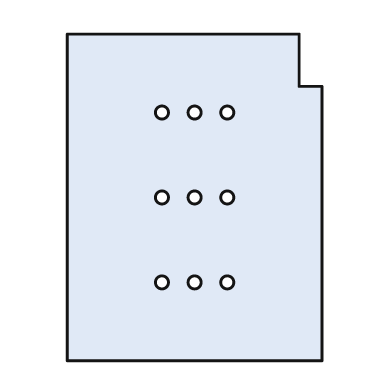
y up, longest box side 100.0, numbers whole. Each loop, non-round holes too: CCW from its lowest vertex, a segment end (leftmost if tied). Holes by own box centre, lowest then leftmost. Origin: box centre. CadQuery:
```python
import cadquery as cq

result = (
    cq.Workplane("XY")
    .moveTo(-39.0, -50.0)
    .lineTo(39.0, -50.0)
    .lineTo(39.0, 34.0)
    .lineTo(32.0, 34.0)
    .lineTo(32.0, 50.0)
    .lineTo(-39.0, 50.0)
    .close()
    .moveTo(-10.0, -26.0)
    .circle(2.0)
    .moveTo(0.0, -26.0)
    .circle(2.0)
    .moveTo(10.0, -26.0)
    .circle(2.0)
    .moveTo(-10.0, 0.0)
    .circle(2.0)
    .moveTo(0.0, 0.0)
    .circle(2.0)
    .moveTo(10.0, 0.0)
    .circle(2.0)
    .moveTo(-10.0, 26.0)
    .circle(2.0)
    .moveTo(0.0, 26.0)
    .circle(2.0)
    .moveTo(10.0, 26.0)
    .circle(2.0)
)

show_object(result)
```